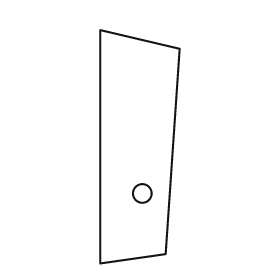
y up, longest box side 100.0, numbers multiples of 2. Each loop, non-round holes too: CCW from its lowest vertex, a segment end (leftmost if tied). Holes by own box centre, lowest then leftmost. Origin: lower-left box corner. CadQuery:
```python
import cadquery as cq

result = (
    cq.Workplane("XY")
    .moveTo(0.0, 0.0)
    .lineTo(28.0, 4.0)
    .lineTo(34.0, 92.0)
    .lineTo(0.0, 100.0)
    .close()
    .moveTo(18.0, 30.0)
    .circle(4.0)
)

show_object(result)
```